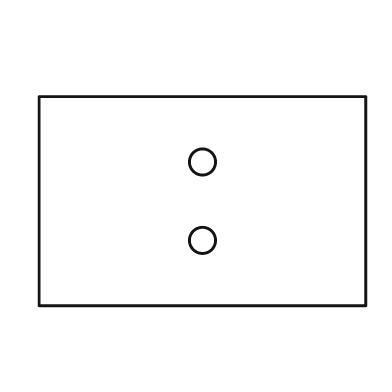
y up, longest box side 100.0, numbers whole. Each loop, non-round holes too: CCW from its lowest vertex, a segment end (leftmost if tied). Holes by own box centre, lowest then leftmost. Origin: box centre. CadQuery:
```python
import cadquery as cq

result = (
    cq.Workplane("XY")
    .moveTo(-50.0, -32.0)
    .lineTo(50.0, -32.0)
    .lineTo(50.0, 32.0)
    .lineTo(-50.0, 32.0)
    .close()
    .moveTo(0.0, -12.0)
    .circle(4.0)
    .moveTo(0.0, 12.0)
    .circle(4.0)
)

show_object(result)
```